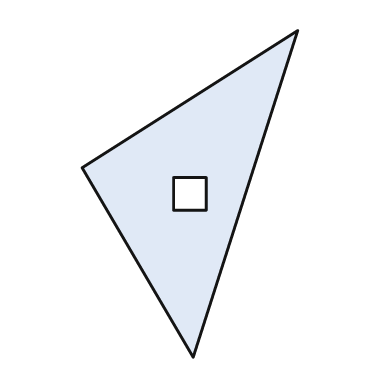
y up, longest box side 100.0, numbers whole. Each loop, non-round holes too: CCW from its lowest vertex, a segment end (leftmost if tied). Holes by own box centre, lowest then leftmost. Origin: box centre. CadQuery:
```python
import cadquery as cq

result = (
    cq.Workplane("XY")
    .moveTo(1.0, -50.0)
    .lineTo(33.0, 50.0)
    .lineTo(-33.0, 8.0)
    .close()
    .moveTo(-5.0, -5.0)
    .lineTo(5.0, -5.0)
    .lineTo(5.0, 5.0)
    .lineTo(-5.0, 5.0)
    .close()
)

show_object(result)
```